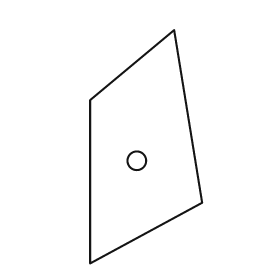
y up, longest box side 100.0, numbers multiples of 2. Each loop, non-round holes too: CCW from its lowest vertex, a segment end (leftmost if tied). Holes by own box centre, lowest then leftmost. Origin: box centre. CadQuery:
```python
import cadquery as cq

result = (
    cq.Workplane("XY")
    .moveTo(-24.0, -50.0)
    .lineTo(24.0, -24.0)
    .lineTo(12.0, 50.0)
    .lineTo(-24.0, 20.0)
    .close()
    .moveTo(-4.0, -6.0)
    .circle(4.0)
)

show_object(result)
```